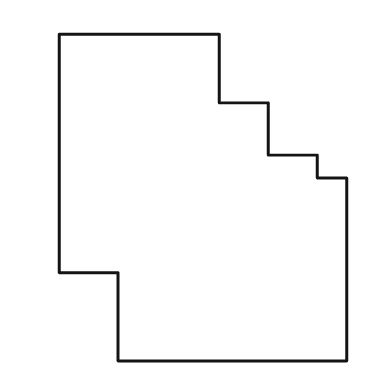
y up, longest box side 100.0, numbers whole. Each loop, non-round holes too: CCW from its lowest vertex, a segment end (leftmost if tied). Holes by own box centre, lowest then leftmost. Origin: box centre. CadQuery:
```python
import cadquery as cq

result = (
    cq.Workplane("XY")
    .moveTo(-26.0, -50.0)
    .lineTo(44.0, -50.0)
    .lineTo(44.0, 6.0)
    .lineTo(35.0, 6.0)
    .lineTo(35.0, 13.0)
    .lineTo(20.0, 13.0)
    .lineTo(20.0, 29.0)
    .lineTo(5.0, 29.0)
    .lineTo(5.0, 50.0)
    .lineTo(-44.0, 50.0)
    .lineTo(-44.0, -23.0)
    .lineTo(-26.0, -23.0)
    .close()
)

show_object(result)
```